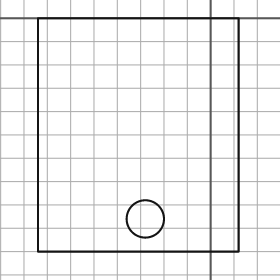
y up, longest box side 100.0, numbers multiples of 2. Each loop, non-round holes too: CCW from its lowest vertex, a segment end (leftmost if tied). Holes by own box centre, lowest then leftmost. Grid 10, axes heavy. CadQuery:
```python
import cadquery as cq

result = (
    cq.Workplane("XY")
    .moveTo(-74.0, -100.0)
    .lineTo(12.0, -100.0)
    .lineTo(12.0, 0.0)
    .lineTo(-74.0, 0.0)
    .close()
    .moveTo(-28.0, -86.0)
    .circle(8.0)
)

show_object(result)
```